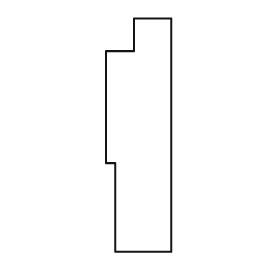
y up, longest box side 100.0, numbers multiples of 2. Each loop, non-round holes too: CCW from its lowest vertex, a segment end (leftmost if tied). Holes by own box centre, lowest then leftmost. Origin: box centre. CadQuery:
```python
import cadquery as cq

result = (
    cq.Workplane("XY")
    .moveTo(-10.0, -50.0)
    .lineTo(14.0, -50.0)
    .lineTo(14.0, 50.0)
    .lineTo(-2.0, 50.0)
    .lineTo(-2.0, 36.0)
    .lineTo(-14.0, 36.0)
    .lineTo(-14.0, -12.0)
    .lineTo(-10.0, -12.0)
    .close()
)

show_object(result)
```